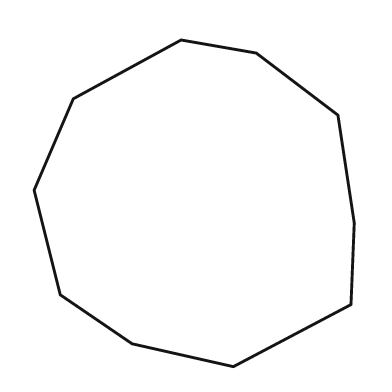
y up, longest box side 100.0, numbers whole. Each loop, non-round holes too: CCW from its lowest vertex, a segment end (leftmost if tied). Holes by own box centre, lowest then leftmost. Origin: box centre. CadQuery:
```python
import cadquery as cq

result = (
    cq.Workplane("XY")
    .moveTo(12.0, -50.0)
    .lineTo(48.0, -31.0)
    .lineTo(49.0, -6.0)
    .lineTo(44.0, 27.0)
    .lineTo(19.0, 46.0)
    .lineTo(-4.0, 50.0)
    .lineTo(-37.0, 32.0)
    .lineTo(-49.0, 4.0)
    .lineTo(-41.0, -28.0)
    .lineTo(-19.0, -43.0)
    .close()
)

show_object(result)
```